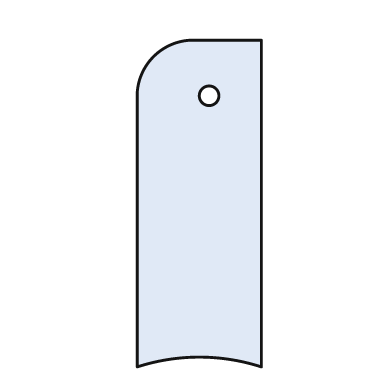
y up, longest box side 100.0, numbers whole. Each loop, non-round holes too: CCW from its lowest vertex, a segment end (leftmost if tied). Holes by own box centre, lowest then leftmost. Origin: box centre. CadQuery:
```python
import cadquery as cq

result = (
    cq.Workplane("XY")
    .moveTo(-19.0, -50.0)
    .threePointArc((0.0, -47.0), (19.0, -50.0))
    .lineTo(19.0, 50.0)
    .lineTo(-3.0, 50.0)
    .threePointArc((-14.0, 45.0), (-19.0, 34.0))
    .close()
    .moveTo(3.0, 33.0)
    .circle(3.0)
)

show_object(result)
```